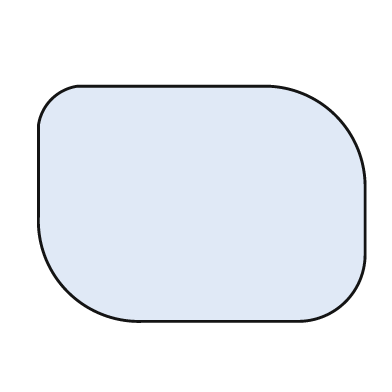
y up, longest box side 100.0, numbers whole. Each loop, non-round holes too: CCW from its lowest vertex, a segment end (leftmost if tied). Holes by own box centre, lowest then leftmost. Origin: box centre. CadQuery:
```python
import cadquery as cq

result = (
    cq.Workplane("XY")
    .moveTo(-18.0, -36.0)
    .lineTo(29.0, -36.0)
    .threePointArc((44.0, -30.0), (50.0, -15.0))
    .lineTo(50.0, 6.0)
    .threePointArc((41.0, 27.0), (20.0, 36.0))
    .lineTo(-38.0, 36.0)
    .threePointArc((-46.0, 32.0), (-50.0, 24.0))
    .lineTo(-50.0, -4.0)
    .threePointArc((-41.0, -27.0), (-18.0, -36.0))
    .close()
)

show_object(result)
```